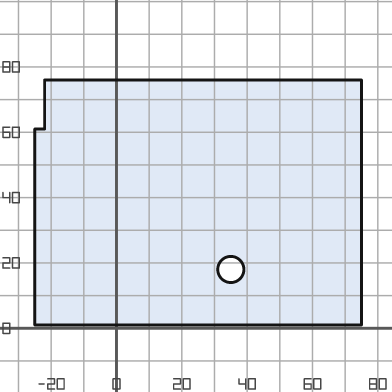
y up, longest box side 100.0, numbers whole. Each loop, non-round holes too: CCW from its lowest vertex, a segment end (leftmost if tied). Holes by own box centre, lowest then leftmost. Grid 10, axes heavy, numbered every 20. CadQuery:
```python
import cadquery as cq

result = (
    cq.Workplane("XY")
    .moveTo(-25.0, 1.0)
    .lineTo(75.0, 1.0)
    .lineTo(75.0, 76.0)
    .lineTo(-22.0, 76.0)
    .lineTo(-22.0, 61.0)
    .lineTo(-25.0, 61.0)
    .close()
    .moveTo(35.0, 18.0)
    .circle(4.0)
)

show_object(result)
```